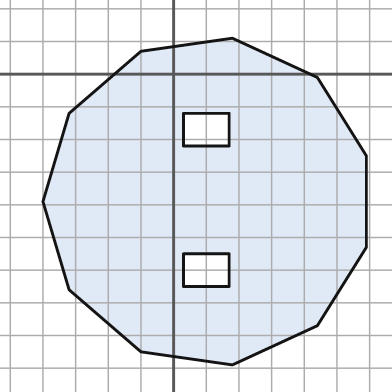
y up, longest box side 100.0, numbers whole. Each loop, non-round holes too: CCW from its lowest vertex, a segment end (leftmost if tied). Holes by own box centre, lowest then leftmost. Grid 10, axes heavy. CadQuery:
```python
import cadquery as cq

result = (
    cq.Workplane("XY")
    .moveTo(18.0, -89.0)
    .lineTo(44.0, -77.0)
    .lineTo(59.0, -53.0)
    .lineTo(59.0, -25.0)
    .lineTo(44.0, -1.0)
    .lineTo(18.0, 11.0)
    .lineTo(-10.0, 7.0)
    .lineTo(-32.0, -12.0)
    .lineTo(-40.0, -39.0)
    .lineTo(-32.0, -66.0)
    .lineTo(-10.0, -85.0)
    .close()
    .moveTo(3.0, -65.0)
    .lineTo(17.0, -65.0)
    .lineTo(17.0, -55.0)
    .lineTo(3.0, -55.0)
    .close()
    .moveTo(3.0, -22.0)
    .lineTo(17.0, -22.0)
    .lineTo(17.0, -12.0)
    .lineTo(3.0, -12.0)
    .close()
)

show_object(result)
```